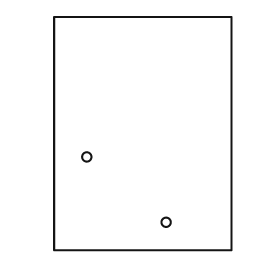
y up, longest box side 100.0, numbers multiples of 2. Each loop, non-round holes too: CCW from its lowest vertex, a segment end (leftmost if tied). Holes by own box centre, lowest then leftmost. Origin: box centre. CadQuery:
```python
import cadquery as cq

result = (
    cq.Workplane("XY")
    .moveTo(-38.0, -50.0)
    .lineTo(38.0, -50.0)
    .lineTo(38.0, 50.0)
    .lineTo(-38.0, 50.0)
    .close()
    .moveTo(10.0, -38.0)
    .circle(2.0)
    .moveTo(-24.0, -10.0)
    .circle(2.0)
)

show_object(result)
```